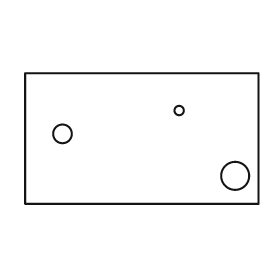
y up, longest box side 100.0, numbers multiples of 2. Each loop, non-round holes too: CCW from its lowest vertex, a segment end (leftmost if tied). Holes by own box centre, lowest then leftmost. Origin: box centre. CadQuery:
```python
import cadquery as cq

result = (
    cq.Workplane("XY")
    .moveTo(-50.0, -28.0)
    .lineTo(50.0, -28.0)
    .lineTo(50.0, 28.0)
    .lineTo(-50.0, 28.0)
    .close()
    .moveTo(40.0, -16.0)
    .circle(6.0)
    .moveTo(-34.0, 2.0)
    .circle(4.0)
    .moveTo(16.0, 12.0)
    .circle(2.0)
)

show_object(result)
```